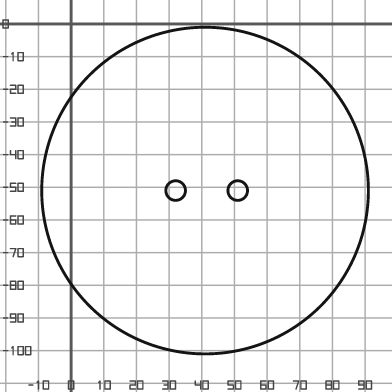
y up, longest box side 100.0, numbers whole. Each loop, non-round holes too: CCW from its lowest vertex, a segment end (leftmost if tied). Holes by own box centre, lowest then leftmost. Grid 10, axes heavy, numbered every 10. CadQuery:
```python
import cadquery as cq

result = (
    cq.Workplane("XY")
    .moveTo(41.0, -51.0)
    .circle(50.0)
    .moveTo(32.0, -51.0)
    .circle(3.0)
    .moveTo(51.0, -51.0)
    .circle(3.0)
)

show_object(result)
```